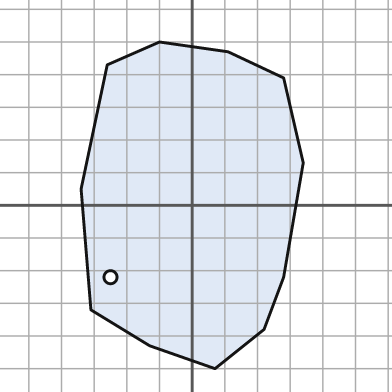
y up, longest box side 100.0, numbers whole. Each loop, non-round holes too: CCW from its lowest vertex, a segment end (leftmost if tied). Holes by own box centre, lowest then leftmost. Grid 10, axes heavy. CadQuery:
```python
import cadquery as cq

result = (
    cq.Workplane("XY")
    .moveTo(7.0, -50.0)
    .lineTo(22.0, -38.0)
    .lineTo(28.0, -22.0)
    .lineTo(34.0, 13.0)
    .lineTo(28.0, 39.0)
    .lineTo(11.0, 47.0)
    .lineTo(-10.0, 50.0)
    .lineTo(-26.0, 43.0)
    .lineTo(-34.0, 5.0)
    .lineTo(-31.0, -32.0)
    .lineTo(-13.0, -43.0)
    .close()
    .moveTo(-25.0, -22.0)
    .circle(2.0)
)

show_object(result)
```